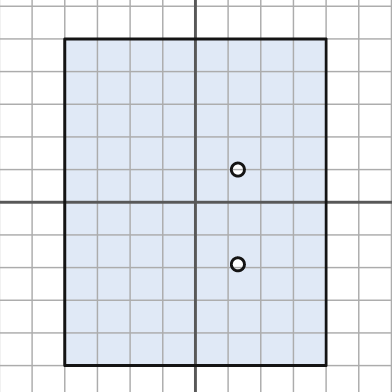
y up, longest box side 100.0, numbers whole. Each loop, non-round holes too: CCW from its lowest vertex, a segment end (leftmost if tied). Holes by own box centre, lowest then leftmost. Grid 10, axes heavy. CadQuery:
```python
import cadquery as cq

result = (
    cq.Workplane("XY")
    .moveTo(-40.0, -50.0)
    .lineTo(40.0, -50.0)
    .lineTo(40.0, 50.0)
    .lineTo(-40.0, 50.0)
    .close()
    .moveTo(13.0, -19.0)
    .circle(2.0)
    .moveTo(13.0, 10.0)
    .circle(2.0)
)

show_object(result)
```